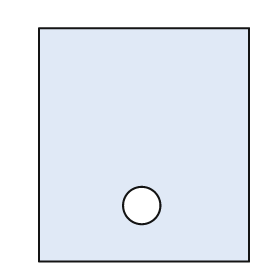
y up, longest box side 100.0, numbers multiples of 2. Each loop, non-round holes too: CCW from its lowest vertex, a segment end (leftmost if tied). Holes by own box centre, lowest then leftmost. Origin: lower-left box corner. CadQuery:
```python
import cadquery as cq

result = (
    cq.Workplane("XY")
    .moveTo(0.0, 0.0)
    .lineTo(90.0, 0.0)
    .lineTo(90.0, 100.0)
    .lineTo(0.0, 100.0)
    .close()
    .moveTo(44.0, 24.0)
    .circle(8.0)
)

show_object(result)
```